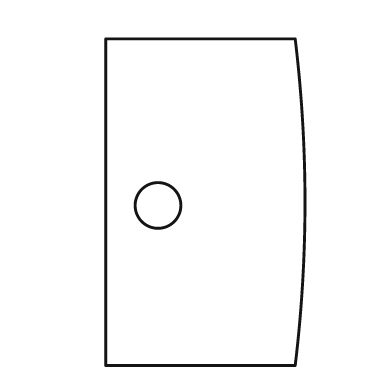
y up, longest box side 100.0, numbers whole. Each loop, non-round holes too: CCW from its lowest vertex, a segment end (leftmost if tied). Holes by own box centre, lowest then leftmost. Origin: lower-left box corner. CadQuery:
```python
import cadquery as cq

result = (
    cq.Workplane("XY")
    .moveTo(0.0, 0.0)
    .lineTo(58.0, 0.0)
    .threePointArc((61.0, 50.0), (58.0, 100.0))
    .lineTo(0.0, 100.0)
    .close()
    .moveTo(16.0, 49.0)
    .circle(7.0)
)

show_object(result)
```